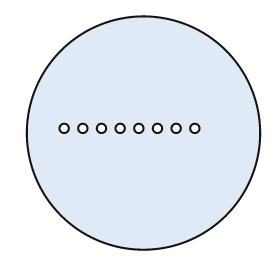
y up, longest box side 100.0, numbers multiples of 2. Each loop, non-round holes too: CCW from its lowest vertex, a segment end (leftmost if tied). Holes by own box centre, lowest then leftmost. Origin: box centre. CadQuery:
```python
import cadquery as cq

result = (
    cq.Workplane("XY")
    .moveTo(0.0, 0.0)
    .circle(50.0)
    .moveTo(-34.0, 2.0)
    .circle(2.0)
    .moveTo(-26.0, 2.0)
    .circle(2.0)
    .moveTo(-18.0, 2.0)
    .circle(2.0)
    .moveTo(-10.0, 2.0)
    .circle(2.0)
    .moveTo(-2.0, 2.0)
    .circle(2.0)
    .moveTo(6.0, 2.0)
    .circle(2.0)
    .moveTo(14.0, 2.0)
    .circle(2.0)
    .moveTo(22.0, 2.0)
    .circle(2.0)
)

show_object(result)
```